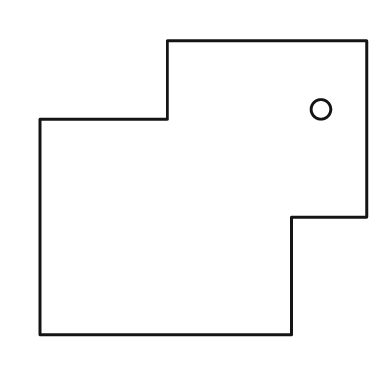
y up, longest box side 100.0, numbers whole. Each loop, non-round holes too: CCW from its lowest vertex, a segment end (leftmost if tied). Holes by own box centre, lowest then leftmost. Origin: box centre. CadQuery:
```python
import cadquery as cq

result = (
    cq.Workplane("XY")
    .moveTo(-50.0, -45.0)
    .lineTo(27.0, -45.0)
    .lineTo(27.0, -9.0)
    .lineTo(50.0, -9.0)
    .lineTo(50.0, 45.0)
    .lineTo(-11.0, 45.0)
    .lineTo(-11.0, 21.0)
    .lineTo(-50.0, 21.0)
    .close()
    .moveTo(36.0, 24.0)
    .circle(3.0)
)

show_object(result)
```